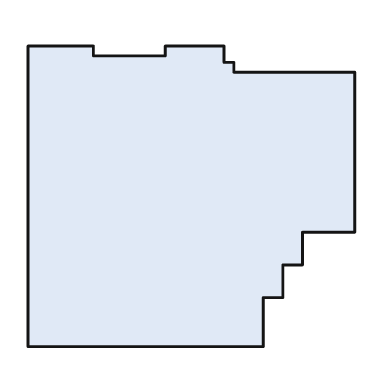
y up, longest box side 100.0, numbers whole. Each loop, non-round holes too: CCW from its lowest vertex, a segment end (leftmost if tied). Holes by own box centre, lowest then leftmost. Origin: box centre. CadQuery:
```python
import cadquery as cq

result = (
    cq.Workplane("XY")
    .moveTo(-50.0, -46.0)
    .lineTo(22.0, -46.0)
    .lineTo(22.0, -31.0)
    .lineTo(28.0, -31.0)
    .lineTo(28.0, -21.0)
    .lineTo(34.0, -21.0)
    .lineTo(34.0, -11.0)
    .lineTo(50.0, -11.0)
    .lineTo(50.0, 38.0)
    .lineTo(13.0, 38.0)
    .lineTo(13.0, 41.0)
    .lineTo(10.0, 41.0)
    .lineTo(10.0, 46.0)
    .lineTo(-8.0, 46.0)
    .lineTo(-8.0, 43.0)
    .lineTo(-30.0, 43.0)
    .lineTo(-30.0, 46.0)
    .lineTo(-50.0, 46.0)
    .close()
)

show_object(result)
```